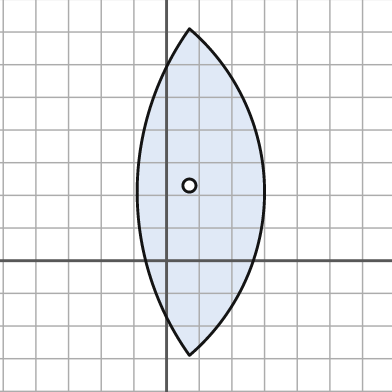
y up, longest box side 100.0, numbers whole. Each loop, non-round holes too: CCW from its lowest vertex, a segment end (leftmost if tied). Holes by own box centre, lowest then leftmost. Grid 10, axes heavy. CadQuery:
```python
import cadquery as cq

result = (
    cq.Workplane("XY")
    .moveTo(7.0, -29.0)
    .threePointArc((30.0, 21.0), (7.0, 71.0))
    .threePointArc((-9.0, 21.0), (7.0, -29.0))
    .close()
    .moveTo(7.0, 23.0)
    .circle(2.0)
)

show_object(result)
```